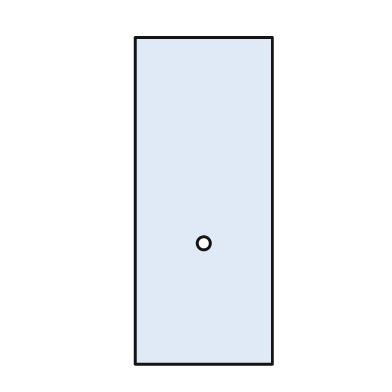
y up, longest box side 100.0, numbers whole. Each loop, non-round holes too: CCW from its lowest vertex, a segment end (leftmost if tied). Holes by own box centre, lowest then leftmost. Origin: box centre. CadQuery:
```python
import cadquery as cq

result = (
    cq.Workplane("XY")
    .moveTo(-21.0, -50.0)
    .lineTo(21.0, -50.0)
    .lineTo(21.0, 50.0)
    .lineTo(-21.0, 50.0)
    .close()
    .moveTo(0.0, -13.0)
    .circle(2.0)
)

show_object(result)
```